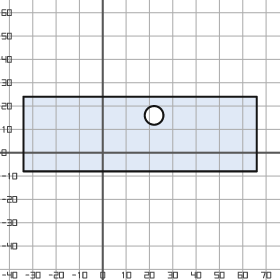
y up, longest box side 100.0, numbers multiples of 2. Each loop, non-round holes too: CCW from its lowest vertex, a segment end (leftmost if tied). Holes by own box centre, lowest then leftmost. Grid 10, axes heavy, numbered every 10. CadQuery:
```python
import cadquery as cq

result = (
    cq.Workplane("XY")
    .moveTo(-34.0, -8.0)
    .lineTo(66.0, -8.0)
    .lineTo(66.0, 24.0)
    .lineTo(-34.0, 24.0)
    .close()
    .moveTo(22.0, 16.0)
    .circle(4.0)
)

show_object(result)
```